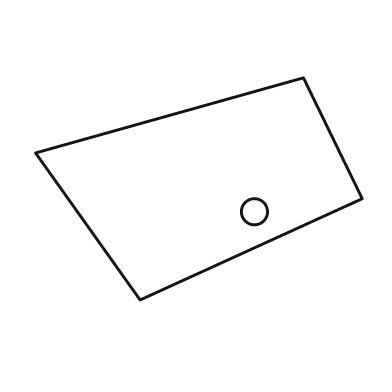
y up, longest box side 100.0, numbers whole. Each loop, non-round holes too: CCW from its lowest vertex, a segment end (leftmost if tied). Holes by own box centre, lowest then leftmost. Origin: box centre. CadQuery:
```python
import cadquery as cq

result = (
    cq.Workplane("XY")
    .moveTo(-18.0, -34.0)
    .lineTo(50.0, -3.0)
    .lineTo(32.0, 34.0)
    .lineTo(-50.0, 11.0)
    .close()
    .moveTo(17.0, -7.0)
    .circle(4.0)
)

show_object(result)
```